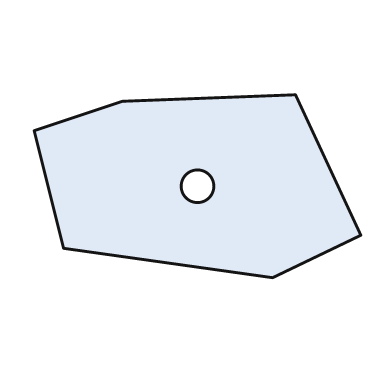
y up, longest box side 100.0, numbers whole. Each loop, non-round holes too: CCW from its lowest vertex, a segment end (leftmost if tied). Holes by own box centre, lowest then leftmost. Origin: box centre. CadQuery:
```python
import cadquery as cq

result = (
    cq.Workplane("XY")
    .moveTo(23.0, -28.0)
    .lineTo(50.0, -15.0)
    .lineTo(30.0, 28.0)
    .lineTo(-23.0, 26.0)
    .lineTo(-50.0, 17.0)
    .lineTo(-41.0, -19.0)
    .close()
    .moveTo(0.0, 0.0)
    .circle(5.0)
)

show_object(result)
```